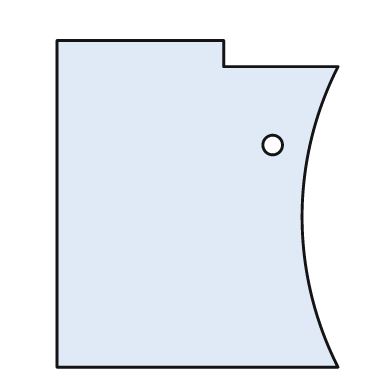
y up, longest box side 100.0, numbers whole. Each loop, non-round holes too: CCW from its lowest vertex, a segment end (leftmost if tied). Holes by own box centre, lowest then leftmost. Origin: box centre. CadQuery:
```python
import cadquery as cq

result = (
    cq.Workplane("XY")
    .moveTo(-43.0, -50.0)
    .lineTo(43.0, -50.0)
    .threePointArc((32.0, -4.0), (43.0, 42.0))
    .lineTo(8.0, 42.0)
    .lineTo(8.0, 50.0)
    .lineTo(-43.0, 50.0)
    .close()
    .moveTo(23.0, 18.0)
    .circle(3.0)
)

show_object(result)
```